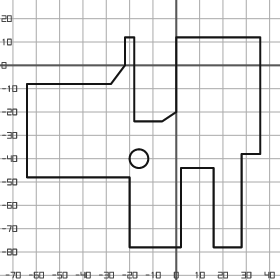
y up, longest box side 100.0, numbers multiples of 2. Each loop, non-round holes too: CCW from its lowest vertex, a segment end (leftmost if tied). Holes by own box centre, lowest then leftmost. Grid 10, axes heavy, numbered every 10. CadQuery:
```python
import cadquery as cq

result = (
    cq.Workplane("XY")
    .moveTo(-20.0, -78.0)
    .lineTo(2.0, -78.0)
    .lineTo(2.0, -44.0)
    .lineTo(16.0, -44.0)
    .lineTo(16.0, -78.0)
    .lineTo(28.0, -78.0)
    .lineTo(28.0, -38.0)
    .lineTo(36.0, -38.0)
    .lineTo(36.0, 12.0)
    .lineTo(0.0, 12.0)
    .lineTo(0.0, -20.0)
    .lineTo(-6.0, -24.0)
    .lineTo(-18.0, -24.0)
    .lineTo(-18.0, 12.0)
    .lineTo(-22.0, 12.0)
    .lineTo(-22.0, 0.0)
    .lineTo(-28.0, -8.0)
    .lineTo(-64.0, -8.0)
    .lineTo(-64.0, -48.0)
    .lineTo(-20.0, -48.0)
    .close()
    .moveTo(-16.0, -40.0)
    .circle(4.0)
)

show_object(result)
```